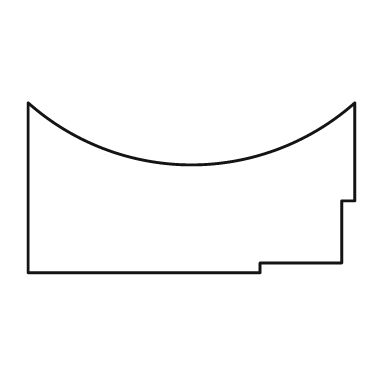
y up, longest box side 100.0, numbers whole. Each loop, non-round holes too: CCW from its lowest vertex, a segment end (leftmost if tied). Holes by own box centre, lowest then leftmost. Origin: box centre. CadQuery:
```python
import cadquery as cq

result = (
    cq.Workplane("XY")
    .moveTo(-50.0, -26.0)
    .lineTo(21.0, -26.0)
    .lineTo(21.0, -23.0)
    .lineTo(46.0, -23.0)
    .lineTo(46.0, -4.0)
    .lineTo(50.0, -4.0)
    .lineTo(50.0, 26.0)
    .threePointArc((0.0, 7.0), (-50.0, 26.0))
    .close()
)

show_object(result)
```